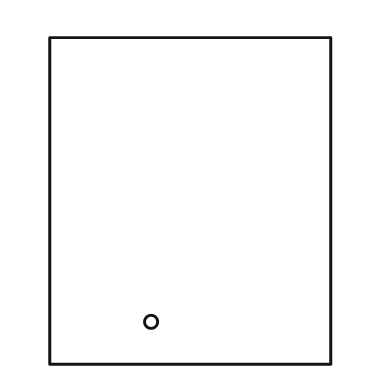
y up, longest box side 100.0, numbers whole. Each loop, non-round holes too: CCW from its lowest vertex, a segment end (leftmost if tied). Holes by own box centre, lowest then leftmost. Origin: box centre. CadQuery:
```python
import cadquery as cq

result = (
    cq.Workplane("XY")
    .moveTo(-43.0, -50.0)
    .lineTo(43.0, -50.0)
    .lineTo(43.0, 50.0)
    .lineTo(-43.0, 50.0)
    .close()
    .moveTo(-12.0, -37.0)
    .circle(2.0)
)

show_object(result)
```